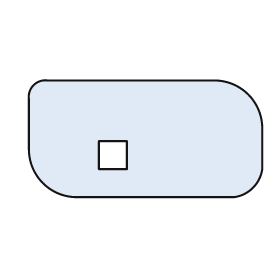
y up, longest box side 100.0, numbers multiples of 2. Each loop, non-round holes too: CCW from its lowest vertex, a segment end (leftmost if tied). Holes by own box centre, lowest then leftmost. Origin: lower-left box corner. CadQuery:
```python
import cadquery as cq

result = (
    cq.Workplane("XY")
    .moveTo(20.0, 0.0)
    .lineTo(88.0, 0.0)
    .threePointArc((96.0, 4.0), (100.0, 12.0))
    .lineTo(100.0, 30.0)
    .threePointArc((94.0, 44.0), (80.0, 50.0))
    .lineTo(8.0, 50.0)
    .threePointArc((2.0, 48.0), (0.0, 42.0))
    .lineTo(0.0, 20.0)
    .threePointArc((6.0, 6.0), (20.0, 0.0))
    .close()
    .moveTo(30.0, 12.0)
    .lineTo(42.0, 12.0)
    .lineTo(42.0, 24.0)
    .lineTo(30.0, 24.0)
    .close()
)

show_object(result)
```